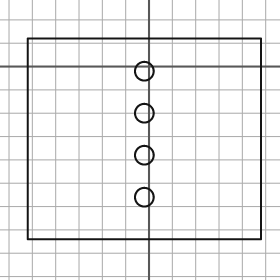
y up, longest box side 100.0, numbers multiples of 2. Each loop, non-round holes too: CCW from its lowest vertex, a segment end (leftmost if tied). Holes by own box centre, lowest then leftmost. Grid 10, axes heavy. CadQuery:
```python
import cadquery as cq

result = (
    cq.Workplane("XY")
    .moveTo(-52.0, -74.0)
    .lineTo(48.0, -74.0)
    .lineTo(48.0, 12.0)
    .lineTo(-52.0, 12.0)
    .close()
    .moveTo(-2.0, -56.0)
    .circle(4.0)
    .moveTo(-2.0, -38.0)
    .circle(4.0)
    .moveTo(-2.0, -20.0)
    .circle(4.0)
    .moveTo(-2.0, -2.0)
    .circle(4.0)
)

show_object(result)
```